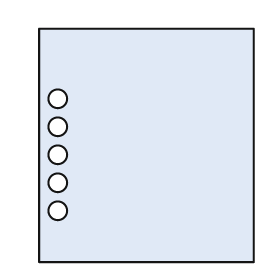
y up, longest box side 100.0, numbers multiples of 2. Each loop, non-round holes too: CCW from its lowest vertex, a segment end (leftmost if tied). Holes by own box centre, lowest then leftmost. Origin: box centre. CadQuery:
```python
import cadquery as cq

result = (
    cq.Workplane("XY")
    .moveTo(-46.0, -50.0)
    .lineTo(46.0, -50.0)
    .lineTo(46.0, 50.0)
    .lineTo(-46.0, 50.0)
    .close()
    .moveTo(-38.0, -28.0)
    .circle(4.0)
    .moveTo(-38.0, -16.0)
    .circle(4.0)
    .moveTo(-38.0, -4.0)
    .circle(4.0)
    .moveTo(-38.0, 8.0)
    .circle(4.0)
    .moveTo(-38.0, 20.0)
    .circle(4.0)
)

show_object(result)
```